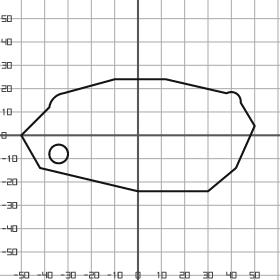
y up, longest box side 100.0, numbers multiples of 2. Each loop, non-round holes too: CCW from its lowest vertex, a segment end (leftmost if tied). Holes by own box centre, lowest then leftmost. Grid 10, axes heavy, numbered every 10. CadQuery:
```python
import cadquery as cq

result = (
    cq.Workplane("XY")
    .moveTo(0.0, -24.0)
    .lineTo(30.0, -24.0)
    .lineTo(42.0, -14.0)
    .lineTo(50.0, 4.0)
    .lineTo(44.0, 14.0)
    .threePointArc((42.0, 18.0), (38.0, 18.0))
    .lineTo(12.0, 24.0)
    .lineTo(-10.0, 24.0)
    .lineTo(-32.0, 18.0)
    .threePointArc((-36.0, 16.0), (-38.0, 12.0))
    .lineTo(-50.0, 0.0)
    .lineTo(-42.0, -14.0)
    .close()
    .moveTo(-34.0, -8.0)
    .circle(4.0)
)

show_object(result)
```